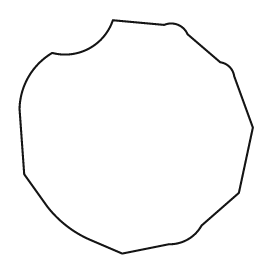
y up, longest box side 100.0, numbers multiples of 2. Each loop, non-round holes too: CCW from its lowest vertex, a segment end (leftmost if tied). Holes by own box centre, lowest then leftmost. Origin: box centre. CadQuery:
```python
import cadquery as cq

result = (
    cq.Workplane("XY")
    .moveTo(-6.0, -50.0)
    .lineTo(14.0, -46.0)
    .threePointArc((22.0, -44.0), (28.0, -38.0))
    .lineTo(44.0, -24.0)
    .lineTo(50.0, 4.0)
    .lineTo(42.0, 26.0)
    .threePointArc((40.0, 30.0), (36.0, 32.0))
    .lineTo(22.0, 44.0)
    .threePointArc((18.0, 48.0), (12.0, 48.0))
    .lineTo(-10.0, 50.0)
    .threePointArc((-20.0, 38.0), (-36.0, 36.0))
    .threePointArc((-46.0, 26.0), (-50.0, 12.0))
    .lineTo(-48.0, -16.0)
    .lineTo(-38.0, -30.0)
    .threePointArc((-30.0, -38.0), (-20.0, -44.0))
    .close()
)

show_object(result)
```